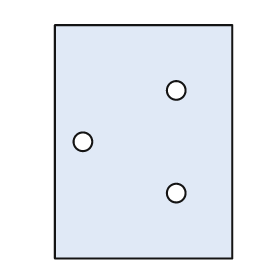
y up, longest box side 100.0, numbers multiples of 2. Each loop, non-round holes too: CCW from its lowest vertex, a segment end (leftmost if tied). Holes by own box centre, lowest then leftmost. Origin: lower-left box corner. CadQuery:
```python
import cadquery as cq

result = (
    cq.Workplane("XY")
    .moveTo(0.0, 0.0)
    .lineTo(76.0, 0.0)
    .lineTo(76.0, 100.0)
    .lineTo(0.0, 100.0)
    .close()
    .moveTo(52.0, 28.0)
    .circle(4.0)
    .moveTo(12.0, 50.0)
    .circle(4.0)
    .moveTo(52.0, 72.0)
    .circle(4.0)
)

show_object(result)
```